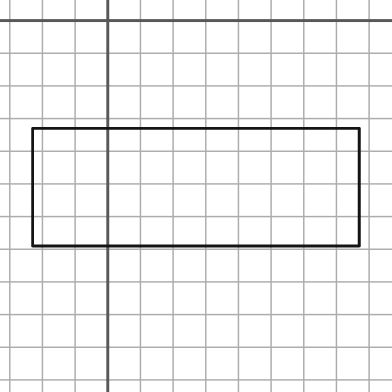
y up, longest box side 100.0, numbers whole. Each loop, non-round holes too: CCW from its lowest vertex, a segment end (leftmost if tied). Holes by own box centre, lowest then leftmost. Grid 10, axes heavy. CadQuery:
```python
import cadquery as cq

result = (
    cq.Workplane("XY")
    .moveTo(-23.0, -69.0)
    .lineTo(77.0, -69.0)
    .lineTo(77.0, -33.0)
    .lineTo(-23.0, -33.0)
    .close()
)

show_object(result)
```